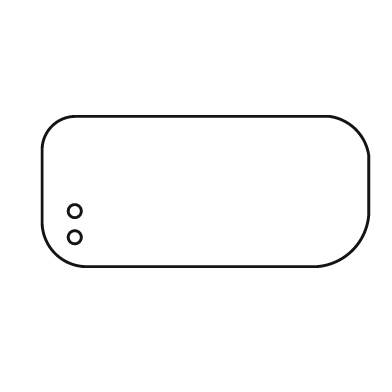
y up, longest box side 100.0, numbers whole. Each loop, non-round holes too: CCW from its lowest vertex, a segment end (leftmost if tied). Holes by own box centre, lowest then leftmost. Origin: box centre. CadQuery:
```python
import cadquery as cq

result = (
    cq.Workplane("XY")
    .moveTo(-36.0, -23.0)
    .lineTo(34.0, -23.0)
    .threePointArc((45.0, -18.0), (50.0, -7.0))
    .lineTo(50.0, 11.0)
    .threePointArc((46.0, 19.0), (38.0, 23.0))
    .lineTo(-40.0, 23.0)
    .threePointArc((-47.0, 20.0), (-50.0, 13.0))
    .lineTo(-50.0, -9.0)
    .threePointArc((-46.0, -19.0), (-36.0, -23.0))
    .close()
    .moveTo(-40.0, -14.0)
    .circle(2.0)
    .moveTo(-40.0, -6.0)
    .circle(2.0)
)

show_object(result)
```